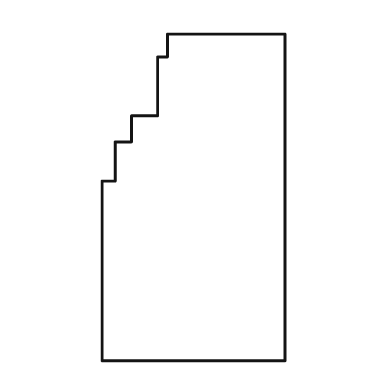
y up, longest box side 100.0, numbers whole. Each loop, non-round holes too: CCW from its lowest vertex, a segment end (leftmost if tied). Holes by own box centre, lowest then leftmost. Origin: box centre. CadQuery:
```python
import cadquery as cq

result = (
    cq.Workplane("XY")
    .moveTo(-28.0, -50.0)
    .lineTo(28.0, -50.0)
    .lineTo(28.0, 50.0)
    .lineTo(-8.0, 50.0)
    .lineTo(-8.0, 43.0)
    .lineTo(-11.0, 43.0)
    .lineTo(-11.0, 25.0)
    .lineTo(-19.0, 25.0)
    .lineTo(-19.0, 17.0)
    .lineTo(-24.0, 17.0)
    .lineTo(-24.0, 5.0)
    .lineTo(-28.0, 5.0)
    .close()
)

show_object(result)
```